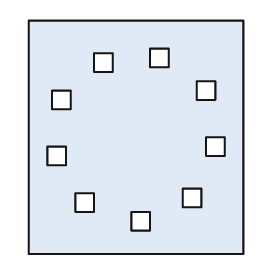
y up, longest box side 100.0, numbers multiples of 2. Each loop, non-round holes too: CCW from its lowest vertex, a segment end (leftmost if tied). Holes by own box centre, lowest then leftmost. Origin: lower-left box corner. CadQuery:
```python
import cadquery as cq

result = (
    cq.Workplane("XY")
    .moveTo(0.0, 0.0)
    .lineTo(92.0, 0.0)
    .lineTo(92.0, 100.0)
    .lineTo(0.0, 100.0)
    .close()
    .moveTo(44.0, 10.0)
    .lineTo(52.0, 10.0)
    .lineTo(52.0, 18.0)
    .lineTo(44.0, 18.0)
    .close()
    .moveTo(20.0, 18.0)
    .lineTo(28.0, 18.0)
    .lineTo(28.0, 26.0)
    .lineTo(20.0, 26.0)
    .close()
    .moveTo(66.0, 20.0)
    .lineTo(74.0, 20.0)
    .lineTo(74.0, 28.0)
    .lineTo(66.0, 28.0)
    .close()
    .moveTo(8.0, 38.0)
    .lineTo(16.0, 38.0)
    .lineTo(16.0, 46.0)
    .lineTo(8.0, 46.0)
    .close()
    .moveTo(76.0, 42.0)
    .lineTo(84.0, 42.0)
    .lineTo(84.0, 50.0)
    .lineTo(76.0, 50.0)
    .close()
    .moveTo(10.0, 62.0)
    .lineTo(18.0, 62.0)
    .lineTo(18.0, 70.0)
    .lineTo(10.0, 70.0)
    .close()
    .moveTo(72.0, 66.0)
    .lineTo(80.0, 66.0)
    .lineTo(80.0, 74.0)
    .lineTo(72.0, 74.0)
    .close()
    .moveTo(28.0, 78.0)
    .lineTo(36.0, 78.0)
    .lineTo(36.0, 86.0)
    .lineTo(28.0, 86.0)
    .close()
    .moveTo(52.0, 80.0)
    .lineTo(60.0, 80.0)
    .lineTo(60.0, 88.0)
    .lineTo(52.0, 88.0)
    .close()
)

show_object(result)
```